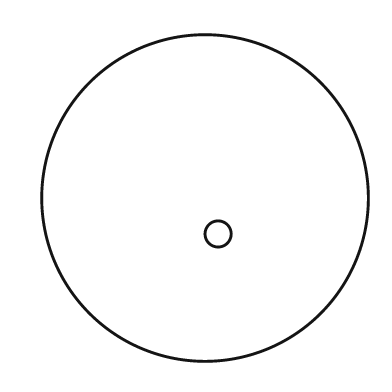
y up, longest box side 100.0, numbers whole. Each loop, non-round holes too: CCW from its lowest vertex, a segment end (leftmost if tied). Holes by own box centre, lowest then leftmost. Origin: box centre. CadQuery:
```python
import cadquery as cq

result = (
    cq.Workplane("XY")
    .moveTo(0.0, 0.0)
    .circle(50.0)
    .moveTo(4.0, -11.0)
    .circle(4.0)
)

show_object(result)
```